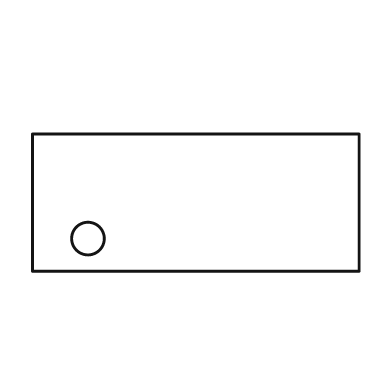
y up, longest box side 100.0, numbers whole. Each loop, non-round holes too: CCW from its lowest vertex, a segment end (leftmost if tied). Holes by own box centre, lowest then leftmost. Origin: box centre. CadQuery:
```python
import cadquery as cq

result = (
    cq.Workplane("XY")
    .moveTo(-50.0, -21.0)
    .lineTo(50.0, -21.0)
    .lineTo(50.0, 21.0)
    .lineTo(-50.0, 21.0)
    .close()
    .moveTo(-33.0, -11.0)
    .circle(5.0)
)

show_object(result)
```